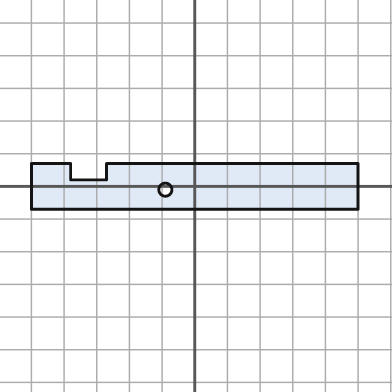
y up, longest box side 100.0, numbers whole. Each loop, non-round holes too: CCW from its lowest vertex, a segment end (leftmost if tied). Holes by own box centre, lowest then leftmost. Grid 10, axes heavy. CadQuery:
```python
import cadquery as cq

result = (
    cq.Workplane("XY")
    .moveTo(-50.0, -7.0)
    .lineTo(50.0, -7.0)
    .lineTo(50.0, 7.0)
    .lineTo(-27.0, 7.0)
    .lineTo(-27.0, 2.0)
    .lineTo(-38.0, 2.0)
    .lineTo(-38.0, 7.0)
    .lineTo(-50.0, 7.0)
    .close()
    .moveTo(-9.0, -1.0)
    .circle(2.0)
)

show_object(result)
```